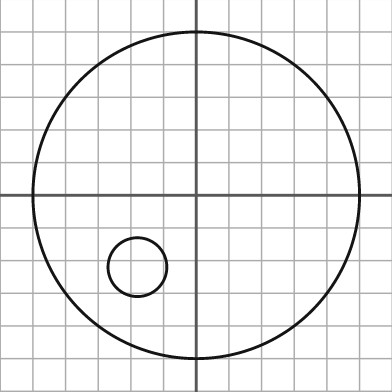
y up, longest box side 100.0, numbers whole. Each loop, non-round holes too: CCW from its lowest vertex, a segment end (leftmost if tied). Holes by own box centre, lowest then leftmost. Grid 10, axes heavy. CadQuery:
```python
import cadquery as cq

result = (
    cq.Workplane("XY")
    .moveTo(0.0, 0.0)
    .circle(50.0)
    .moveTo(-18.0, -22.0)
    .circle(9.0)
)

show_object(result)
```